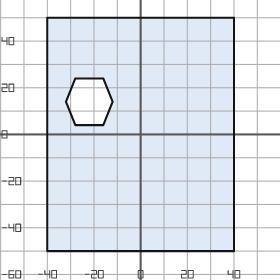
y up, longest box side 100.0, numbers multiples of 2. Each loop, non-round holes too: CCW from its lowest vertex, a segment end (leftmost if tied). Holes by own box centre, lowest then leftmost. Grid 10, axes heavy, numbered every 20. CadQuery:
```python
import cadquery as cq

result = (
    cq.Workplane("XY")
    .moveTo(-40.0, -50.0)
    .lineTo(40.0, -50.0)
    .lineTo(40.0, 50.0)
    .lineTo(-40.0, 50.0)
    .close()
    .moveTo(-28.0, 4.0)
    .lineTo(-16.0, 4.0)
    .lineTo(-12.0, 14.0)
    .lineTo(-16.0, 24.0)
    .lineTo(-28.0, 24.0)
    .lineTo(-32.0, 14.0)
    .close()
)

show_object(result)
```